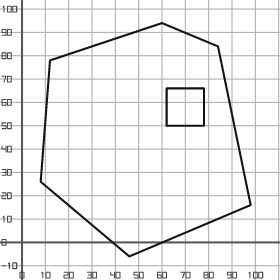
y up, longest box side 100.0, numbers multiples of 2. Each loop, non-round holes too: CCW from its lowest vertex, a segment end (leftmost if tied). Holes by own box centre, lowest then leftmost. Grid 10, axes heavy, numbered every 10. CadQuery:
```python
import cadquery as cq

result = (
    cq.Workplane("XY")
    .moveTo(46.0, -6.0)
    .lineTo(98.0, 16.0)
    .lineTo(84.0, 84.0)
    .lineTo(60.0, 94.0)
    .lineTo(12.0, 78.0)
    .lineTo(8.0, 26.0)
    .close()
    .moveTo(62.0, 50.0)
    .lineTo(78.0, 50.0)
    .lineTo(78.0, 66.0)
    .lineTo(62.0, 66.0)
    .close()
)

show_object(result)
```